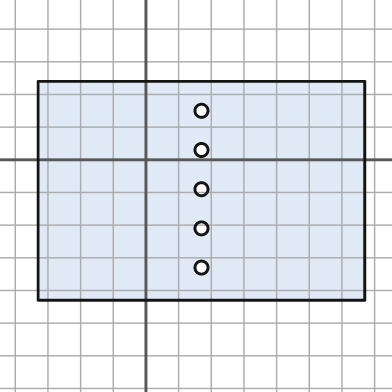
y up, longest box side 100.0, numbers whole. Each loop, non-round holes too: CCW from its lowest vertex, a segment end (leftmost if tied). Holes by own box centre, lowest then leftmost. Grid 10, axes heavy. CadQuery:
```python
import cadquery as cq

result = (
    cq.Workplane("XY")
    .moveTo(-33.0, -43.0)
    .lineTo(67.0, -43.0)
    .lineTo(67.0, 24.0)
    .lineTo(-33.0, 24.0)
    .close()
    .moveTo(17.0, -33.0)
    .circle(2.0)
    .moveTo(17.0, -21.0)
    .circle(2.0)
    .moveTo(17.0, -9.0)
    .circle(2.0)
    .moveTo(17.0, 3.0)
    .circle(2.0)
    .moveTo(17.0, 15.0)
    .circle(2.0)
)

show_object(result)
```